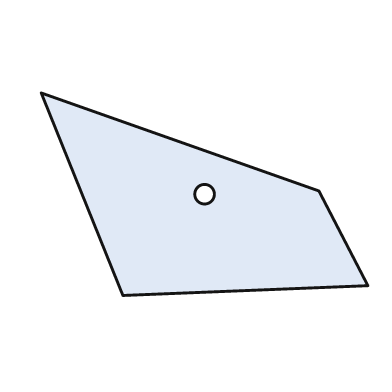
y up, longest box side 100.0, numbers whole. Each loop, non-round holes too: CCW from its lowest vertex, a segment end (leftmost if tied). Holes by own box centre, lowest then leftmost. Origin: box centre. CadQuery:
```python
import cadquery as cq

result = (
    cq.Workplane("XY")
    .moveTo(-25.0, -31.0)
    .lineTo(50.0, -28.0)
    .lineTo(35.0, 1.0)
    .lineTo(-50.0, 31.0)
    .close()
    .moveTo(0.0, 0.0)
    .circle(3.0)
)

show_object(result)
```